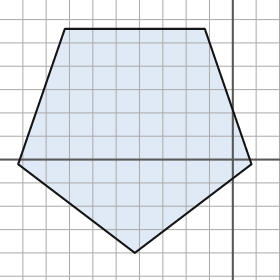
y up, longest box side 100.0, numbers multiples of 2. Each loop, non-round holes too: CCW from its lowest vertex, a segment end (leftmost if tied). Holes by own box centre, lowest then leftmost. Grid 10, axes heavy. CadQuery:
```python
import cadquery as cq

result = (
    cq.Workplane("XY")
    .moveTo(-42.0, -40.0)
    .lineTo(8.0, -2.0)
    .lineTo(-12.0, 56.0)
    .lineTo(-72.0, 56.0)
    .lineTo(-92.0, -2.0)
    .close()
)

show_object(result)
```